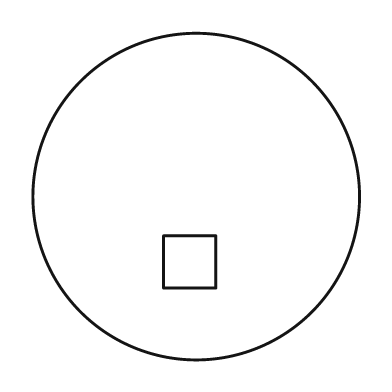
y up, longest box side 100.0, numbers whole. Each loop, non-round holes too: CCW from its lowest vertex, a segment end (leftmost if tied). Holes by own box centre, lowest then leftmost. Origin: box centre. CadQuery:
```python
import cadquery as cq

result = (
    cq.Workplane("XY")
    .moveTo(0.0, 0.0)
    .circle(50.0)
    .moveTo(-10.0, -28.0)
    .lineTo(6.0, -28.0)
    .lineTo(6.0, -12.0)
    .lineTo(-10.0, -12.0)
    .close()
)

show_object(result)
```